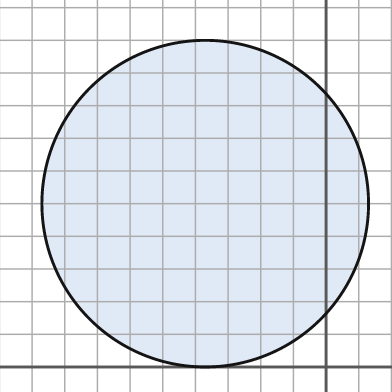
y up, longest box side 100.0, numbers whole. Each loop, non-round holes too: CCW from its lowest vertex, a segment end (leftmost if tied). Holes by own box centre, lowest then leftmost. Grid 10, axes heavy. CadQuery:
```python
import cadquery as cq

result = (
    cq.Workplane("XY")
    .moveTo(-37.0, 50.0)
    .circle(50.0)
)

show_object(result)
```